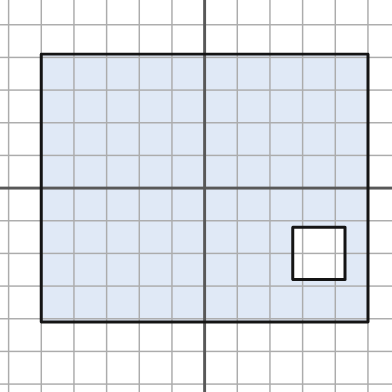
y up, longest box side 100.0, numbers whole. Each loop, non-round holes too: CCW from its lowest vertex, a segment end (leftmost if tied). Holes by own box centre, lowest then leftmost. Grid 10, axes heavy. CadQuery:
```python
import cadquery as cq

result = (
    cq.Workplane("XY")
    .moveTo(-50.0, -41.0)
    .lineTo(50.0, -41.0)
    .lineTo(50.0, 41.0)
    .lineTo(-50.0, 41.0)
    .close()
    .moveTo(27.0, -28.0)
    .lineTo(43.0, -28.0)
    .lineTo(43.0, -12.0)
    .lineTo(27.0, -12.0)
    .close()
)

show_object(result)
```